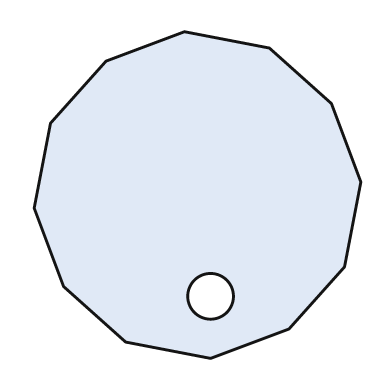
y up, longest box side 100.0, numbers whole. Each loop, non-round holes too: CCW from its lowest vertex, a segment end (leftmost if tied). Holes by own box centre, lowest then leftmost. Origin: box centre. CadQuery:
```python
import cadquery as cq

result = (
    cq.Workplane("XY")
    .moveTo(4.0, -50.0)
    .lineTo(28.0, -41.0)
    .lineTo(45.0, -22.0)
    .lineTo(50.0, 4.0)
    .lineTo(41.0, 28.0)
    .lineTo(22.0, 45.0)
    .lineTo(-4.0, 50.0)
    .lineTo(-28.0, 41.0)
    .lineTo(-45.0, 22.0)
    .lineTo(-50.0, -4.0)
    .lineTo(-41.0, -28.0)
    .lineTo(-22.0, -45.0)
    .close()
    .moveTo(4.0, -31.0)
    .circle(7.0)
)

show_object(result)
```